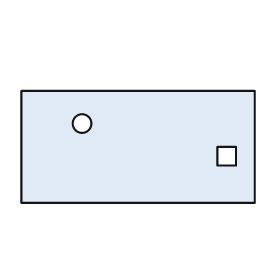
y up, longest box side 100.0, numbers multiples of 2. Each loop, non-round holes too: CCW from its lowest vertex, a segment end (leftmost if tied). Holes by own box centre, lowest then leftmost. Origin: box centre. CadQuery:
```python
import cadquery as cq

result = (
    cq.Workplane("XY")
    .moveTo(-50.0, -24.0)
    .lineTo(50.0, -24.0)
    .lineTo(50.0, 24.0)
    .lineTo(-50.0, 24.0)
    .close()
    .moveTo(34.0, -8.0)
    .lineTo(42.0, -8.0)
    .lineTo(42.0, 0.0)
    .lineTo(34.0, 0.0)
    .close()
    .moveTo(-24.0, 10.0)
    .circle(4.0)
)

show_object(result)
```